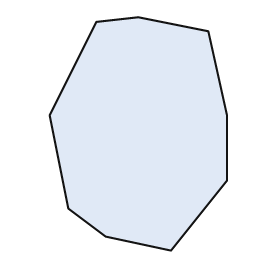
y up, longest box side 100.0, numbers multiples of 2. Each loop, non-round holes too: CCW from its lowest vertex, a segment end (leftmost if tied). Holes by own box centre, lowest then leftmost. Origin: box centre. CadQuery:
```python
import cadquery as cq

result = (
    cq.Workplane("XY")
    .moveTo(14.0, -50.0)
    .lineTo(38.0, -20.0)
    .lineTo(38.0, 8.0)
    .lineTo(30.0, 44.0)
    .lineTo(0.0, 50.0)
    .lineTo(-18.0, 48.0)
    .lineTo(-38.0, 8.0)
    .lineTo(-30.0, -32.0)
    .lineTo(-14.0, -44.0)
    .close()
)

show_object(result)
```